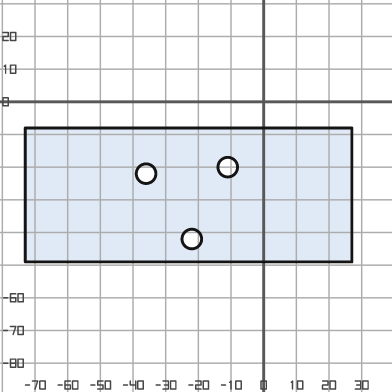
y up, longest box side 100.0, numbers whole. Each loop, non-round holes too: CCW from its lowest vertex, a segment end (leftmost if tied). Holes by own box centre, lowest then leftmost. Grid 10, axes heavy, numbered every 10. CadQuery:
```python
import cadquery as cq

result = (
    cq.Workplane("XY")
    .moveTo(-73.0, -49.0)
    .lineTo(27.0, -49.0)
    .lineTo(27.0, -8.0)
    .lineTo(-73.0, -8.0)
    .close()
    .moveTo(-22.0, -42.0)
    .circle(3.0)
    .moveTo(-36.0, -22.0)
    .circle(3.0)
    .moveTo(-11.0, -20.0)
    .circle(3.0)
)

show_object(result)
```